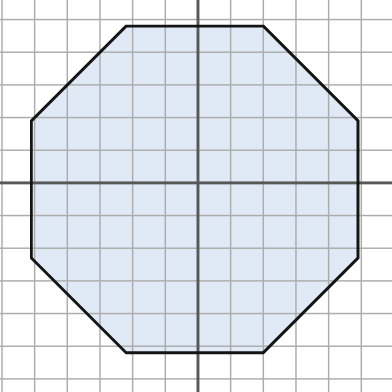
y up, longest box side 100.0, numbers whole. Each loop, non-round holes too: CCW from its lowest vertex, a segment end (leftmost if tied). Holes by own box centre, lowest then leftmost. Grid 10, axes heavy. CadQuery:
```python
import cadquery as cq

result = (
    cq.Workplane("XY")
    .moveTo(-22.0, -52.0)
    .lineTo(20.0, -52.0)
    .lineTo(49.0, -23.0)
    .lineTo(49.0, 19.0)
    .lineTo(20.0, 48.0)
    .lineTo(-22.0, 48.0)
    .lineTo(-51.0, 19.0)
    .lineTo(-51.0, -23.0)
    .close()
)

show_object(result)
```